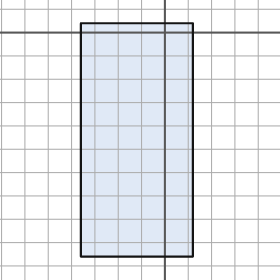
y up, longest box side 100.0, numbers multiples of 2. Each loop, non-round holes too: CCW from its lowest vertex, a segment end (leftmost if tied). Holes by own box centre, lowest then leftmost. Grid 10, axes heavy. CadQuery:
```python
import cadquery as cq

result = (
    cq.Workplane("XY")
    .moveTo(-36.0, -96.0)
    .lineTo(12.0, -96.0)
    .lineTo(12.0, 4.0)
    .lineTo(-36.0, 4.0)
    .close()
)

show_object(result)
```